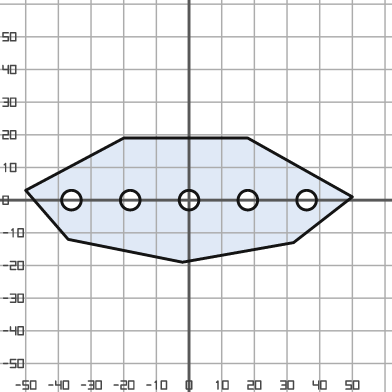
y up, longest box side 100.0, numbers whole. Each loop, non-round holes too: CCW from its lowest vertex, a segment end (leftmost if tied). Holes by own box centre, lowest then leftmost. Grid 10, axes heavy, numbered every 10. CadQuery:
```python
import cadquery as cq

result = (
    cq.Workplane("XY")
    .moveTo(-2.0, -19.0)
    .lineTo(32.0, -13.0)
    .lineTo(50.0, 1.0)
    .lineTo(18.0, 19.0)
    .lineTo(-20.0, 19.0)
    .lineTo(-50.0, 3.0)
    .lineTo(-37.0, -12.0)
    .close()
    .moveTo(-36.0, 0.0)
    .circle(3.0)
    .moveTo(-18.0, 0.0)
    .circle(3.0)
    .moveTo(0.0, 0.0)
    .circle(3.0)
    .moveTo(18.0, 0.0)
    .circle(3.0)
    .moveTo(36.0, 0.0)
    .circle(3.0)
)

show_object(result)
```